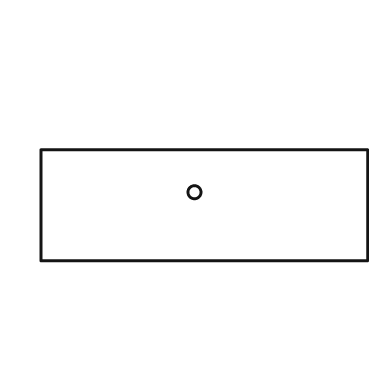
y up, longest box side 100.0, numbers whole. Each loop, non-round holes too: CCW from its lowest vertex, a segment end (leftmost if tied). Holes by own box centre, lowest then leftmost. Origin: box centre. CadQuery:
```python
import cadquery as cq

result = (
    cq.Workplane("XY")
    .moveTo(-50.0, -17.0)
    .lineTo(50.0, -17.0)
    .lineTo(50.0, 17.0)
    .lineTo(-50.0, 17.0)
    .close()
    .moveTo(-3.0, 4.0)
    .circle(2.0)
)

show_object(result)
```